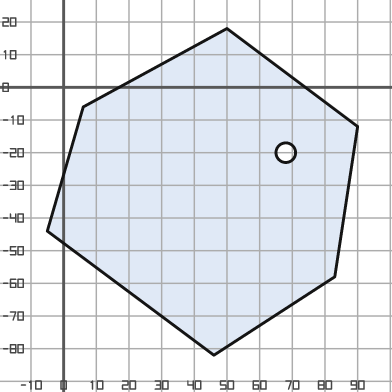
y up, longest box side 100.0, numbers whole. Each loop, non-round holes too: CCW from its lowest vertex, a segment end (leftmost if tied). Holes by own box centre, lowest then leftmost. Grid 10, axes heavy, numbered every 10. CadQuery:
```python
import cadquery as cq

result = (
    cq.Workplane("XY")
    .moveTo(46.0, -82.0)
    .lineTo(83.0, -58.0)
    .lineTo(90.0, -12.0)
    .lineTo(50.0, 18.0)
    .lineTo(6.0, -6.0)
    .lineTo(-5.0, -44.0)
    .close()
    .moveTo(68.0, -20.0)
    .circle(3.0)
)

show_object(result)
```